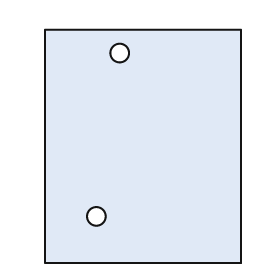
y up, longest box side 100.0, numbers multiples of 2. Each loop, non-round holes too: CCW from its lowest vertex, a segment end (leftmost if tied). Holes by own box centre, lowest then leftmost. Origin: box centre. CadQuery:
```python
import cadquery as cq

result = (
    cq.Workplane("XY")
    .moveTo(-42.0, -50.0)
    .lineTo(42.0, -50.0)
    .lineTo(42.0, 50.0)
    .lineTo(-42.0, 50.0)
    .close()
    .moveTo(-20.0, -30.0)
    .circle(4.0)
    .moveTo(-10.0, 40.0)
    .circle(4.0)
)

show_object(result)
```